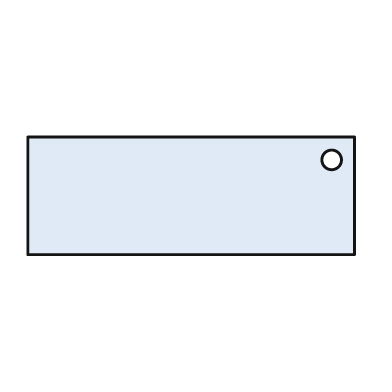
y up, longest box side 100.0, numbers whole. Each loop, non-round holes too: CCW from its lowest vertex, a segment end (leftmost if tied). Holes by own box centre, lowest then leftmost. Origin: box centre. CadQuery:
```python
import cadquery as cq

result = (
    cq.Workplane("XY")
    .moveTo(-50.0, -18.0)
    .lineTo(50.0, -18.0)
    .lineTo(50.0, 18.0)
    .lineTo(-50.0, 18.0)
    .close()
    .moveTo(43.0, 11.0)
    .circle(3.0)
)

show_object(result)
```